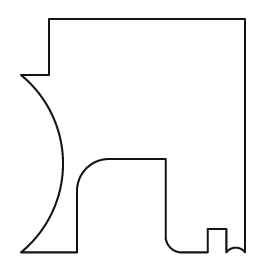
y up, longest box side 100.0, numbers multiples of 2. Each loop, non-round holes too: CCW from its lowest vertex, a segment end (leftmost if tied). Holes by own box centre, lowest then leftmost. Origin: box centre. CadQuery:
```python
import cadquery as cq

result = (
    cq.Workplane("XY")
    .moveTo(-48.0, -50.0)
    .lineTo(-24.0, -50.0)
    .lineTo(-24.0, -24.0)
    .threePointArc((-20.0, -14.0), (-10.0, -10.0))
    .lineTo(14.0, -10.0)
    .lineTo(14.0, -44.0)
    .threePointArc((16.0, -48.0), (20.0, -50.0))
    .lineTo(32.0, -50.0)
    .lineTo(32.0, -40.0)
    .lineTo(40.0, -40.0)
    .lineTo(40.0, -50.0)
    .threePointArc((44.0, -48.0), (48.0, -50.0))
    .lineTo(48.0, 50.0)
    .lineTo(-36.0, 50.0)
    .lineTo(-36.0, 26.0)
    .lineTo(-48.0, 26.0)
    .threePointArc((-30.0, -12.0), (-48.0, -50.0))
    .close()
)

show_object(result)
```